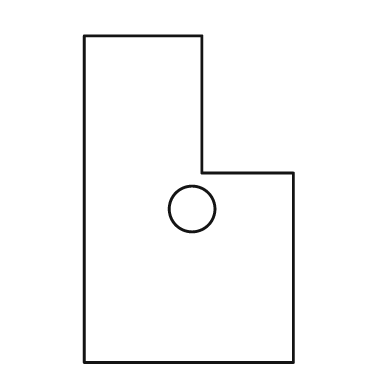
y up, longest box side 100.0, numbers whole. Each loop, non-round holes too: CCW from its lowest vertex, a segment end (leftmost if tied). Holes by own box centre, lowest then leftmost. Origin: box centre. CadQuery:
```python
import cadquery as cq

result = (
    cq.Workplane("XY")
    .moveTo(-32.0, -50.0)
    .lineTo(32.0, -50.0)
    .lineTo(32.0, 8.0)
    .lineTo(4.0, 8.0)
    .lineTo(4.0, 50.0)
    .lineTo(-32.0, 50.0)
    .close()
    .moveTo(1.0, -3.0)
    .circle(7.0)
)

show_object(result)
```